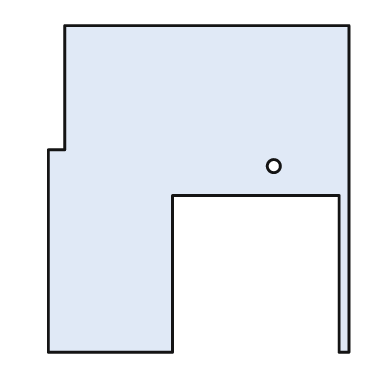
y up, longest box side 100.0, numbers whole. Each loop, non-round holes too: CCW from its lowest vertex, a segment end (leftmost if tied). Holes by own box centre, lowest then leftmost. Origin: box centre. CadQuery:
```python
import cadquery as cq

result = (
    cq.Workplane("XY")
    .moveTo(-46.0, -50.0)
    .lineTo(-8.0, -50.0)
    .lineTo(-8.0, -2.0)
    .lineTo(43.0, -2.0)
    .lineTo(43.0, -50.0)
    .lineTo(46.0, -50.0)
    .lineTo(46.0, 50.0)
    .lineTo(-41.0, 50.0)
    .lineTo(-41.0, 12.0)
    .lineTo(-46.0, 12.0)
    .close()
    .moveTo(23.0, 7.0)
    .circle(2.0)
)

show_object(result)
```